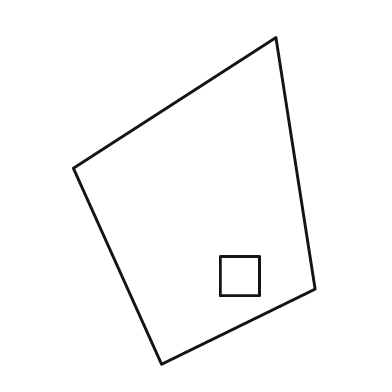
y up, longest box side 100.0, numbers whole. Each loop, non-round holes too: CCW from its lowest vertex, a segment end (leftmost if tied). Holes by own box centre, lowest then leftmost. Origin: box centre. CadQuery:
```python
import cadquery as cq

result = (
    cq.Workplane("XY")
    .moveTo(-10.0, -50.0)
    .lineTo(37.0, -27.0)
    .lineTo(25.0, 50.0)
    .lineTo(-37.0, 10.0)
    .close()
    .moveTo(8.0, -29.0)
    .lineTo(20.0, -29.0)
    .lineTo(20.0, -17.0)
    .lineTo(8.0, -17.0)
    .close()
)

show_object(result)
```